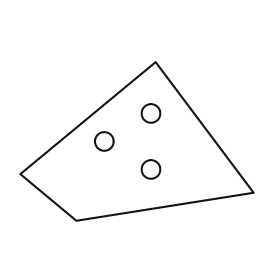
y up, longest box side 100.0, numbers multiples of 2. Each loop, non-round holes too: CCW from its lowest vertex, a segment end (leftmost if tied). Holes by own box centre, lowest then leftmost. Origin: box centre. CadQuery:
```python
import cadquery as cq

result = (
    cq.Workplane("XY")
    .moveTo(-26.0, -34.0)
    .lineTo(50.0, -22.0)
    .lineTo(8.0, 34.0)
    .lineTo(-50.0, -14.0)
    .close()
    .moveTo(6.0, -12.0)
    .circle(4.0)
    .moveTo(-14.0, 0.0)
    .circle(4.0)
    .moveTo(6.0, 12.0)
    .circle(4.0)
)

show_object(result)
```